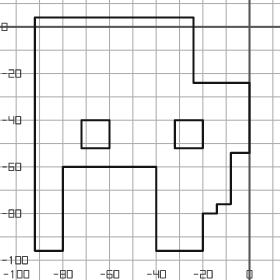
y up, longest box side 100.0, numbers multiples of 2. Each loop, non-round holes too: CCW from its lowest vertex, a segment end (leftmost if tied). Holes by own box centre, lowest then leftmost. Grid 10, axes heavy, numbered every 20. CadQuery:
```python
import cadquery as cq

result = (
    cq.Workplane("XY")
    .moveTo(-92.0, -96.0)
    .lineTo(-80.0, -96.0)
    .lineTo(-80.0, -60.0)
    .lineTo(-40.0, -60.0)
    .lineTo(-40.0, -96.0)
    .lineTo(-20.0, -96.0)
    .lineTo(-20.0, -80.0)
    .lineTo(-14.0, -80.0)
    .lineTo(-14.0, -76.0)
    .lineTo(-8.0, -76.0)
    .lineTo(-8.0, -54.0)
    .lineTo(0.0, -54.0)
    .lineTo(0.0, -24.0)
    .lineTo(-24.0, -24.0)
    .lineTo(-24.0, 4.0)
    .lineTo(-92.0, 4.0)
    .close()
    .moveTo(-72.0, -52.0)
    .lineTo(-60.0, -52.0)
    .lineTo(-60.0, -40.0)
    .lineTo(-72.0, -40.0)
    .close()
    .moveTo(-32.0, -52.0)
    .lineTo(-20.0, -52.0)
    .lineTo(-20.0, -40.0)
    .lineTo(-32.0, -40.0)
    .close()
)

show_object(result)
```